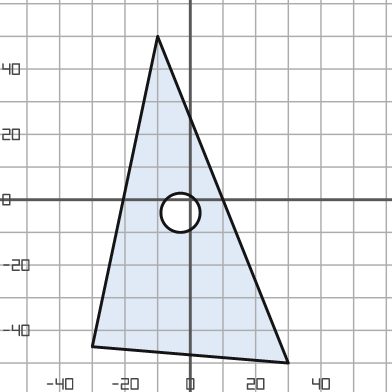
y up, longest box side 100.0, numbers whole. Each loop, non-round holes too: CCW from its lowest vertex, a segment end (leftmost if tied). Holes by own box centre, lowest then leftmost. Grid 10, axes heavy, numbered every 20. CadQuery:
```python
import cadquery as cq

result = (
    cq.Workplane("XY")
    .moveTo(30.0, -50.0)
    .lineTo(-10.0, 50.0)
    .lineTo(-30.0, -45.0)
    .close()
    .moveTo(-3.0, -4.0)
    .circle(6.0)
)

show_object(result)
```